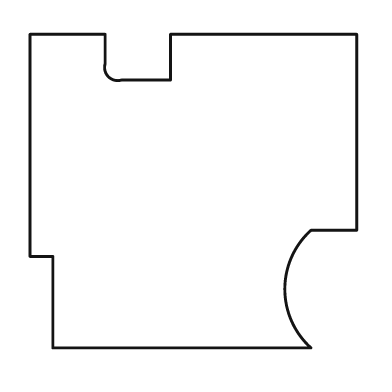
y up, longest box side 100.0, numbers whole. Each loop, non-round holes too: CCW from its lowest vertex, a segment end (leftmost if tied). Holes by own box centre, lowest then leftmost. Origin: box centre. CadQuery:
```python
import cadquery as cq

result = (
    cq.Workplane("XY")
    .moveTo(-43.0, -48.0)
    .lineTo(36.0, -48.0)
    .threePointArc((28.0, -30.0), (36.0, -12.0))
    .lineTo(50.0, -12.0)
    .lineTo(50.0, 48.0)
    .lineTo(-7.0, 48.0)
    .lineTo(-7.0, 34.0)
    .lineTo(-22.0, 34.0)
    .threePointArc((-26.0, 35.0), (-27.0, 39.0))
    .lineTo(-27.0, 48.0)
    .lineTo(-50.0, 48.0)
    .lineTo(-50.0, -20.0)
    .lineTo(-43.0, -20.0)
    .close()
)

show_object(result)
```